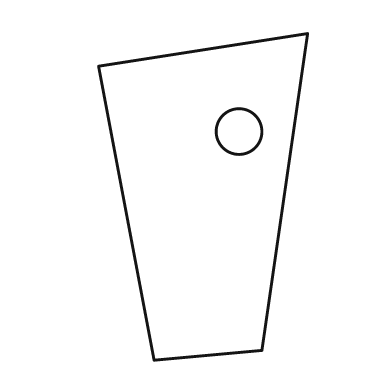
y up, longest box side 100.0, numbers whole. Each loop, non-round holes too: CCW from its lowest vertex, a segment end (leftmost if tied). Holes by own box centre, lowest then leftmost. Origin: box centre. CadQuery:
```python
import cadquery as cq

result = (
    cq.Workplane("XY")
    .moveTo(-15.0, -50.0)
    .lineTo(18.0, -47.0)
    .lineTo(32.0, 50.0)
    .lineTo(-32.0, 40.0)
    .close()
    .moveTo(11.0, 20.0)
    .circle(7.0)
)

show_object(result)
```